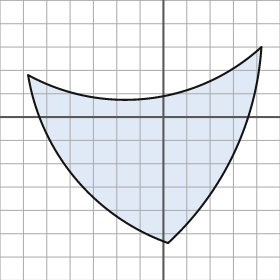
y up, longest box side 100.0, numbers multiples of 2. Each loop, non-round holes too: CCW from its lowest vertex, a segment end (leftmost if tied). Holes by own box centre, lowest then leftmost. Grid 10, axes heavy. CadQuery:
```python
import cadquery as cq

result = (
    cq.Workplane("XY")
    .moveTo(2.0, -54.0)
    .threePointArc((30.0, -16.0), (42.0, 30.0))
    .threePointArc((-6.0, 8.0), (-58.0, 18.0))
    .threePointArc((-38.0, -26.0), (2.0, -54.0))
    .close()
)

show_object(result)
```